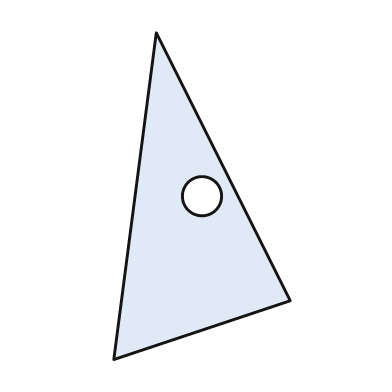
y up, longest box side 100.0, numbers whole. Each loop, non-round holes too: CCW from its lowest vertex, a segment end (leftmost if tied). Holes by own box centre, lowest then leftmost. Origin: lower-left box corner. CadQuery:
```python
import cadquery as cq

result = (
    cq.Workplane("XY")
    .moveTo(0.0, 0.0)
    .lineTo(54.0, 18.0)
    .lineTo(13.0, 100.0)
    .close()
    .moveTo(27.0, 50.0)
    .circle(6.0)
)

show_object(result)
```